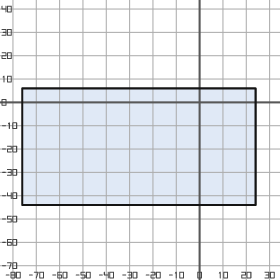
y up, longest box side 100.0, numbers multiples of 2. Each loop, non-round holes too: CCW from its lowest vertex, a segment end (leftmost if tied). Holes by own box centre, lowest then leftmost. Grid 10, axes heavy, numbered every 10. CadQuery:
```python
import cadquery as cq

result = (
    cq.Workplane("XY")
    .moveTo(-76.0, -44.0)
    .lineTo(24.0, -44.0)
    .lineTo(24.0, 6.0)
    .lineTo(-76.0, 6.0)
    .close()
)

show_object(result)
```